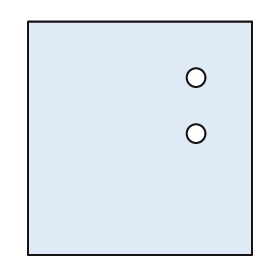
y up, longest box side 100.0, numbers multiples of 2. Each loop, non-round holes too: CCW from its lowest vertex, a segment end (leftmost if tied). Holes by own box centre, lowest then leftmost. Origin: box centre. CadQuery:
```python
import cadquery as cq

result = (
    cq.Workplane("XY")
    .moveTo(-48.0, -50.0)
    .lineTo(48.0, -50.0)
    .lineTo(48.0, 50.0)
    .lineTo(-48.0, 50.0)
    .close()
    .moveTo(24.0, 2.0)
    .circle(4.0)
    .moveTo(24.0, 26.0)
    .circle(4.0)
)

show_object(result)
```